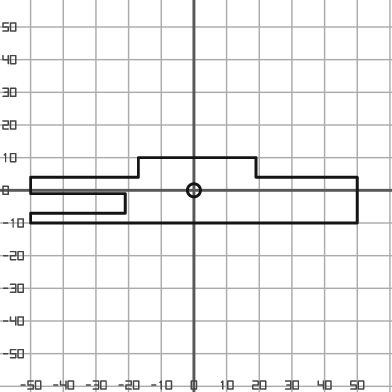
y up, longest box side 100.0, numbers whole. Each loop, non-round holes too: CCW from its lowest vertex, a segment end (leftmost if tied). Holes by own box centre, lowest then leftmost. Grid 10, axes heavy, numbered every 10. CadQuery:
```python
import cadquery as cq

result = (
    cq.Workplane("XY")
    .moveTo(-50.0, -10.0)
    .lineTo(50.0, -10.0)
    .lineTo(50.0, 4.0)
    .lineTo(19.0, 4.0)
    .lineTo(19.0, 10.0)
    .lineTo(-17.0, 10.0)
    .lineTo(-17.0, 4.0)
    .lineTo(-50.0, 4.0)
    .lineTo(-50.0, -1.0)
    .lineTo(-21.0, -1.0)
    .lineTo(-21.0, -7.0)
    .lineTo(-50.0, -7.0)
    .close()
    .moveTo(0.0, 0.0)
    .circle(2.0)
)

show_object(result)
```